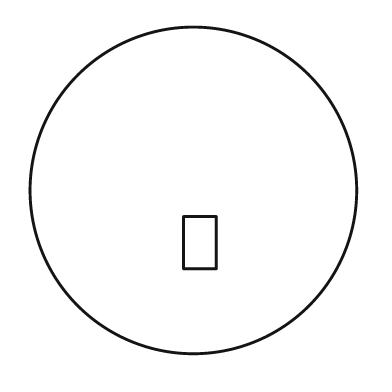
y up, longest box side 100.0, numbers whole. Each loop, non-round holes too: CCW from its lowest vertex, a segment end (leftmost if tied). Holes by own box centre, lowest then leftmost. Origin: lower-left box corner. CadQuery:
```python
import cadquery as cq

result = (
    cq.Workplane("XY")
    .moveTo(50.0, 50.0)
    .circle(50.0)
    .moveTo(47.0, 26.0)
    .lineTo(57.0, 26.0)
    .lineTo(57.0, 42.0)
    .lineTo(47.0, 42.0)
    .close()
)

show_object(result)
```